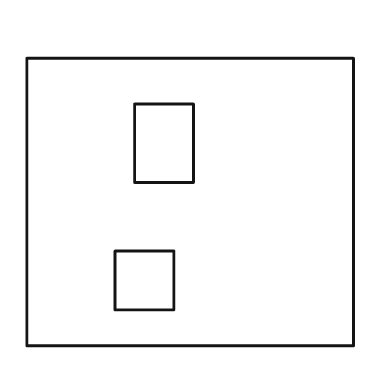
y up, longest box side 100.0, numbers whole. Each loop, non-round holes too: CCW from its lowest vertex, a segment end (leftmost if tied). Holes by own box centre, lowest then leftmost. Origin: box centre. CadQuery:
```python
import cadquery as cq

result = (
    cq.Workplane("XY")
    .moveTo(-50.0, -44.0)
    .lineTo(50.0, -44.0)
    .lineTo(50.0, 44.0)
    .lineTo(-50.0, 44.0)
    .close()
    .moveTo(-23.0, -33.0)
    .lineTo(-5.0, -33.0)
    .lineTo(-5.0, -15.0)
    .lineTo(-23.0, -15.0)
    .close()
    .moveTo(-17.0, 6.0)
    .lineTo(1.0, 6.0)
    .lineTo(1.0, 30.0)
    .lineTo(-17.0, 30.0)
    .close()
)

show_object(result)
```